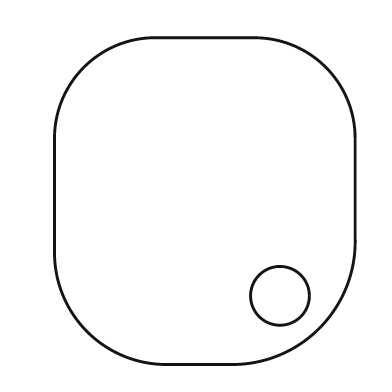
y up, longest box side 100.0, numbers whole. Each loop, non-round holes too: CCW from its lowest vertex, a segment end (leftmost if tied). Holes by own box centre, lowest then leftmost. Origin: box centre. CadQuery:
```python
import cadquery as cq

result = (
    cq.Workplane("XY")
    .moveTo(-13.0, -50.0)
    .lineTo(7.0, -50.0)
    .threePointArc((35.0, -39.0), (46.0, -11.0))
    .lineTo(46.0, 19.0)
    .threePointArc((37.0, 41.0), (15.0, 50.0))
    .lineTo(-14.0, 50.0)
    .threePointArc((-37.0, 41.0), (-46.0, 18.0))
    .lineTo(-46.0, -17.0)
    .threePointArc((-36.0, -40.0), (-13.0, -50.0))
    .close()
    .moveTo(23.0, -29.0)
    .circle(9.0)
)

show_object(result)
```